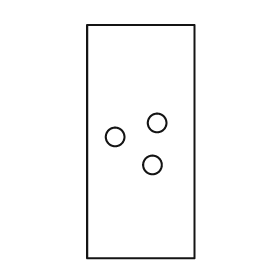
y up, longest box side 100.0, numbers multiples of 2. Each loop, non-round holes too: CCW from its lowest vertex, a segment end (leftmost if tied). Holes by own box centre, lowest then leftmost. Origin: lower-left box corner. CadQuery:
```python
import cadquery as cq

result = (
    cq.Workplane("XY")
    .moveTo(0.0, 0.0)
    .lineTo(46.0, 0.0)
    .lineTo(46.0, 100.0)
    .lineTo(0.0, 100.0)
    .close()
    .moveTo(28.0, 40.0)
    .circle(4.0)
    .moveTo(12.0, 52.0)
    .circle(4.0)
    .moveTo(30.0, 58.0)
    .circle(4.0)
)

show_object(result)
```